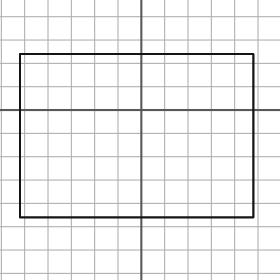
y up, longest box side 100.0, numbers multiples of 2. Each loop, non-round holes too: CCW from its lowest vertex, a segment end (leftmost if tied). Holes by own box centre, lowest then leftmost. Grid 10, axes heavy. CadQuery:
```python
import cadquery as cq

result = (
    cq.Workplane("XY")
    .moveTo(-52.0, -46.0)
    .lineTo(48.0, -46.0)
    .lineTo(48.0, 24.0)
    .lineTo(-52.0, 24.0)
    .close()
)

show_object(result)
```